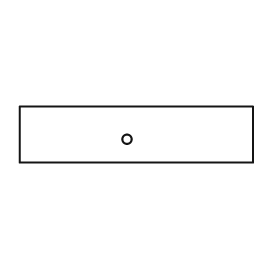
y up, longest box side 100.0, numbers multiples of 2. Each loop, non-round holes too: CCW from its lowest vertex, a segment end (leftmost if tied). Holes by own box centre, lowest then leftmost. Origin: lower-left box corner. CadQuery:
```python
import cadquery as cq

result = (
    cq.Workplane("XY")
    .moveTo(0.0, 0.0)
    .lineTo(100.0, 0.0)
    .lineTo(100.0, 24.0)
    .lineTo(0.0, 24.0)
    .close()
    .moveTo(46.0, 10.0)
    .circle(2.0)
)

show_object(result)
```